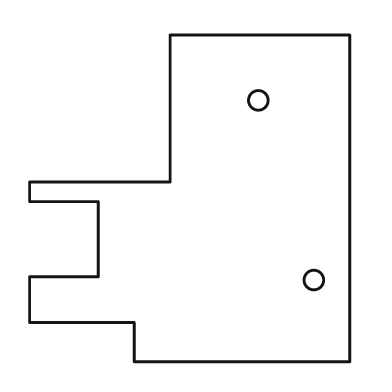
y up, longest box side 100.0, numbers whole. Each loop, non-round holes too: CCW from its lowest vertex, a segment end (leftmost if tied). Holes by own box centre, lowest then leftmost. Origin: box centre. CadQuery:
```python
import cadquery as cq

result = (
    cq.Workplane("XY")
    .moveTo(-17.0, -50.0)
    .lineTo(49.0, -50.0)
    .lineTo(49.0, 50.0)
    .lineTo(-6.0, 50.0)
    .lineTo(-6.0, 5.0)
    .lineTo(-49.0, 5.0)
    .lineTo(-49.0, -1.0)
    .lineTo(-28.0, -1.0)
    .lineTo(-28.0, -24.0)
    .lineTo(-49.0, -24.0)
    .lineTo(-49.0, -38.0)
    .lineTo(-17.0, -38.0)
    .close()
    .moveTo(38.0, -25.0)
    .circle(3.0)
    .moveTo(21.0, 30.0)
    .circle(3.0)
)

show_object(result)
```